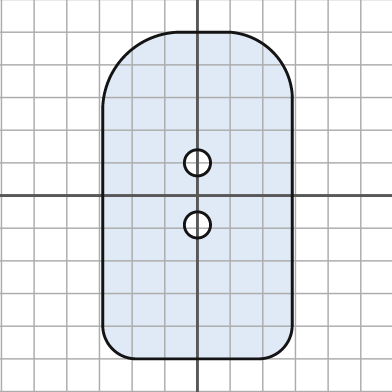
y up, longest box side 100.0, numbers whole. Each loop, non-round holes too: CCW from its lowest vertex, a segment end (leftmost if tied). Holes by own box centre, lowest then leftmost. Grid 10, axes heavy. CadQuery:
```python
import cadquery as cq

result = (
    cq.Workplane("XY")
    .moveTo(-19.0, -50.0)
    .lineTo(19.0, -50.0)
    .threePointArc((26.0, -47.0), (29.0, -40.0))
    .lineTo(29.0, 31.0)
    .threePointArc((23.0, 44.0), (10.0, 50.0))
    .lineTo(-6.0, 50.0)
    .threePointArc((-22.0, 43.0), (-29.0, 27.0))
    .lineTo(-29.0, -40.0)
    .threePointArc((-26.0, -47.0), (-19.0, -50.0))
    .close()
    .moveTo(0.0, -9.0)
    .circle(4.0)
    .moveTo(0.0, 10.0)
    .circle(4.0)
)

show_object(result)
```